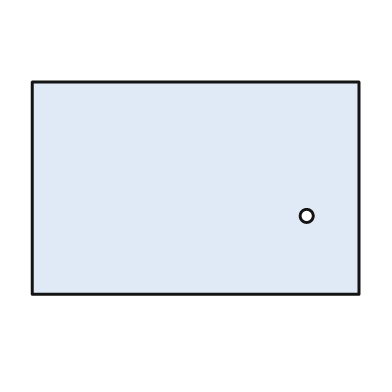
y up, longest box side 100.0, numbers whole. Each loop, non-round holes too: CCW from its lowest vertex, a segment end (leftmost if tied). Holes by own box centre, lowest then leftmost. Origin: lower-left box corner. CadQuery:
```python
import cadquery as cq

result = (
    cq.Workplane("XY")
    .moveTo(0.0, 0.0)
    .lineTo(100.0, 0.0)
    .lineTo(100.0, 65.0)
    .lineTo(0.0, 65.0)
    .close()
    .moveTo(84.0, 24.0)
    .circle(2.0)
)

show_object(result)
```